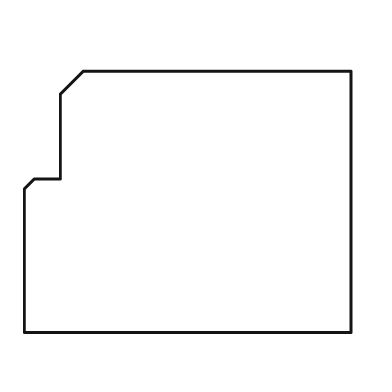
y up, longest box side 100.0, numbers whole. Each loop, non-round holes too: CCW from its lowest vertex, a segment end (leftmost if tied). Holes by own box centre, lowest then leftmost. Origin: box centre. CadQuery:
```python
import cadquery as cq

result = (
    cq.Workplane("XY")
    .moveTo(-50.0, -40.0)
    .lineTo(50.0, -40.0)
    .lineTo(50.0, 40.0)
    .lineTo(-32.0, 40.0)
    .lineTo(-39.0, 33.0)
    .lineTo(-39.0, 7.0)
    .lineTo(-47.0, 7.0)
    .lineTo(-50.0, 4.0)
    .close()
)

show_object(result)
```